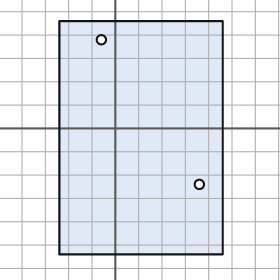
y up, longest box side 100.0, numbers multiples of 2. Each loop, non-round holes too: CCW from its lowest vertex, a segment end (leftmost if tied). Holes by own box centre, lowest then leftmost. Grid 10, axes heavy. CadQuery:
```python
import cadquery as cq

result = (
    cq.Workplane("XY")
    .moveTo(-24.0, -54.0)
    .lineTo(46.0, -54.0)
    .lineTo(46.0, 46.0)
    .lineTo(-24.0, 46.0)
    .close()
    .moveTo(36.0, -24.0)
    .circle(2.0)
    .moveTo(-6.0, 38.0)
    .circle(2.0)
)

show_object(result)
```